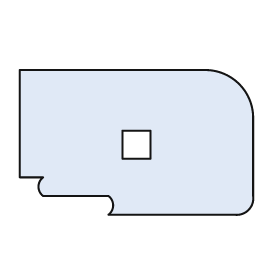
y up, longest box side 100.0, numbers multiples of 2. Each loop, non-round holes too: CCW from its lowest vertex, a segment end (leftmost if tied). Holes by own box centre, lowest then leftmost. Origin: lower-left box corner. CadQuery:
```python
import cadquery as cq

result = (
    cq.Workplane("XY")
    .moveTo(38.0, 0.0)
    .lineTo(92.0, 0.0)
    .threePointArc((98.0, 2.0), (100.0, 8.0))
    .lineTo(100.0, 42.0)
    .threePointArc((94.0, 56.0), (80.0, 62.0))
    .lineTo(0.0, 62.0)
    .lineTo(0.0, 16.0)
    .lineTo(10.0, 16.0)
    .threePointArc((8.0, 12.0), (10.0, 8.0))
    .lineTo(38.0, 8.0)
    .threePointArc((40.0, 4.0), (38.0, 0.0))
    .close()
    .moveTo(44.0, 24.0)
    .lineTo(56.0, 24.0)
    .lineTo(56.0, 36.0)
    .lineTo(44.0, 36.0)
    .close()
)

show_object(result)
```